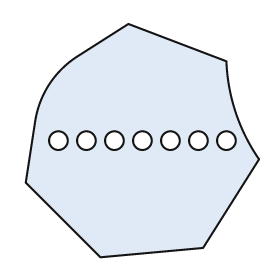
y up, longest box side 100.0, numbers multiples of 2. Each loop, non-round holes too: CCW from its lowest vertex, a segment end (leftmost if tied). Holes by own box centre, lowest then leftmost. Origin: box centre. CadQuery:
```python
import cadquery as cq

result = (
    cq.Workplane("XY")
    .moveTo(-18.0, -50.0)
    .lineTo(26.0, -46.0)
    .lineTo(50.0, -8.0)
    .threePointArc((40.0, 12.0), (36.0, 34.0))
    .lineTo(-6.0, 50.0)
    .lineTo(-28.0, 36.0)
    .threePointArc((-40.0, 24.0), (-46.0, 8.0))
    .lineTo(-50.0, -18.0)
    .close()
    .moveTo(-36.0, 0.0)
    .circle(4.0)
    .moveTo(-24.0, 0.0)
    .circle(4.0)
    .moveTo(-12.0, 0.0)
    .circle(4.0)
    .moveTo(0.0, 0.0)
    .circle(4.0)
    .moveTo(12.0, 0.0)
    .circle(4.0)
    .moveTo(24.0, 0.0)
    .circle(4.0)
    .moveTo(36.0, 0.0)
    .circle(4.0)
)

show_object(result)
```